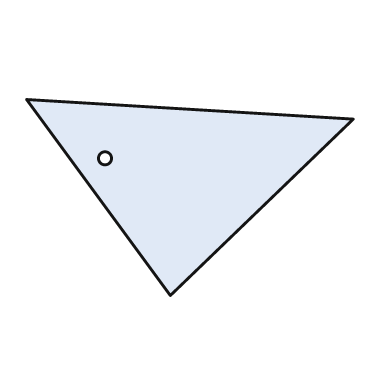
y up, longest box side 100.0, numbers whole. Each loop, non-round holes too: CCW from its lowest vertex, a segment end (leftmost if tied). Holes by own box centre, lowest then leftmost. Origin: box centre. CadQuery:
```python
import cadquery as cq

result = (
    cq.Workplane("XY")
    .moveTo(-6.0, -30.0)
    .lineTo(50.0, 24.0)
    .lineTo(-50.0, 30.0)
    .close()
    .moveTo(-26.0, 12.0)
    .circle(2.0)
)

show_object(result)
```